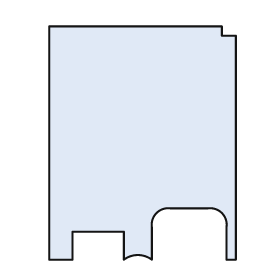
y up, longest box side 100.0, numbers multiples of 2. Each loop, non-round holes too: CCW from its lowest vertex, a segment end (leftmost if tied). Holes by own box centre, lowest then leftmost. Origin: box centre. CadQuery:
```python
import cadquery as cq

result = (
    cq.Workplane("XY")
    .moveTo(-40.0, -50.0)
    .lineTo(-30.0, -50.0)
    .lineTo(-30.0, -38.0)
    .lineTo(-8.0, -38.0)
    .lineTo(-8.0, -50.0)
    .threePointArc((-2.0, -48.0), (4.0, -50.0))
    .lineTo(4.0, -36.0)
    .threePointArc((6.0, -30.0), (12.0, -28.0))
    .lineTo(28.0, -28.0)
    .threePointArc((34.0, -30.0), (36.0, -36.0))
    .lineTo(36.0, -50.0)
    .lineTo(40.0, -50.0)
    .lineTo(40.0, 46.0)
    .lineTo(34.0, 46.0)
    .lineTo(34.0, 50.0)
    .lineTo(-40.0, 50.0)
    .close()
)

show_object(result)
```